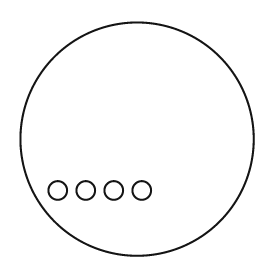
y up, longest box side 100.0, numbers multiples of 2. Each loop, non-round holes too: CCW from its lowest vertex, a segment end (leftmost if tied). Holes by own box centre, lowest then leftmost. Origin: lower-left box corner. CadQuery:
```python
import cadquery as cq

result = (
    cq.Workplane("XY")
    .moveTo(50.0, 50.0)
    .circle(50.0)
    .moveTo(16.0, 28.0)
    .circle(4.0)
    .moveTo(28.0, 28.0)
    .circle(4.0)
    .moveTo(40.0, 28.0)
    .circle(4.0)
    .moveTo(52.0, 28.0)
    .circle(4.0)
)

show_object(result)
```